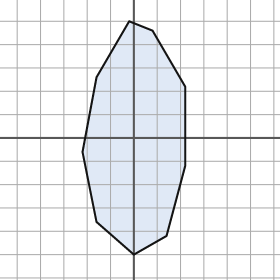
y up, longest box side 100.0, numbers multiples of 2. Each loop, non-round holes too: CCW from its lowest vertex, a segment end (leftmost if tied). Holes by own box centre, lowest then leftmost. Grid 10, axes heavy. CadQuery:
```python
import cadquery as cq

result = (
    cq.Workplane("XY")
    .moveTo(0.0, -50.0)
    .lineTo(14.0, -42.0)
    .lineTo(22.0, -12.0)
    .lineTo(22.0, 22.0)
    .lineTo(8.0, 46.0)
    .lineTo(-2.0, 50.0)
    .lineTo(-16.0, 26.0)
    .lineTo(-22.0, -6.0)
    .lineTo(-16.0, -36.0)
    .close()
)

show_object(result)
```